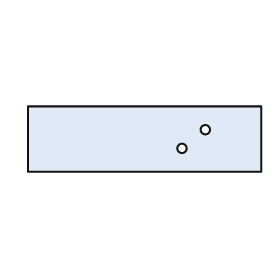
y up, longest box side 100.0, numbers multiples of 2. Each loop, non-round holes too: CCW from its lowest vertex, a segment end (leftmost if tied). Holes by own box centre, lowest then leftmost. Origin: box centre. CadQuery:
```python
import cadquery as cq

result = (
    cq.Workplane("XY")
    .moveTo(-50.0, -14.0)
    .lineTo(50.0, -14.0)
    .lineTo(50.0, 14.0)
    .lineTo(-50.0, 14.0)
    .close()
    .moveTo(16.0, -4.0)
    .circle(2.0)
    .moveTo(26.0, 4.0)
    .circle(2.0)
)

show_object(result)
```